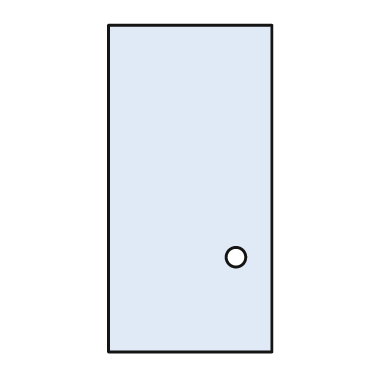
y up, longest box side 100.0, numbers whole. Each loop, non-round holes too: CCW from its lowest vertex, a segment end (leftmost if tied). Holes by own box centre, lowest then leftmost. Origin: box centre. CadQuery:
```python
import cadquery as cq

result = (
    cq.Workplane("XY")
    .moveTo(-25.0, -50.0)
    .lineTo(25.0, -50.0)
    .lineTo(25.0, 50.0)
    .lineTo(-25.0, 50.0)
    .close()
    .moveTo(14.0, -21.0)
    .circle(3.0)
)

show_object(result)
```